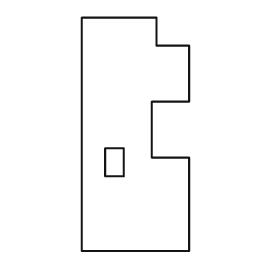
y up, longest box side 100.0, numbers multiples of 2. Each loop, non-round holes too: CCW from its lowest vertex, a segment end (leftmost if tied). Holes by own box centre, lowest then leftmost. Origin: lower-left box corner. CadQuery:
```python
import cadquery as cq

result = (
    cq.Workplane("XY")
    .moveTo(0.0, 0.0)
    .lineTo(46.0, 0.0)
    .lineTo(46.0, 40.0)
    .lineTo(30.0, 40.0)
    .lineTo(30.0, 64.0)
    .lineTo(46.0, 64.0)
    .lineTo(46.0, 88.0)
    .lineTo(32.0, 88.0)
    .lineTo(32.0, 100.0)
    .lineTo(0.0, 100.0)
    .close()
    .moveTo(10.0, 32.0)
    .lineTo(18.0, 32.0)
    .lineTo(18.0, 44.0)
    .lineTo(10.0, 44.0)
    .close()
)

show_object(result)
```